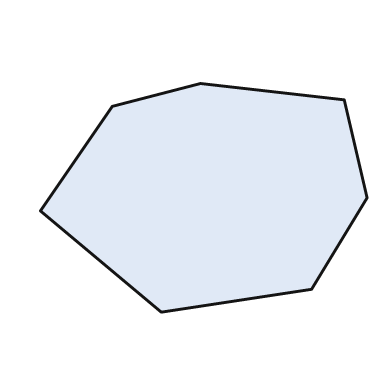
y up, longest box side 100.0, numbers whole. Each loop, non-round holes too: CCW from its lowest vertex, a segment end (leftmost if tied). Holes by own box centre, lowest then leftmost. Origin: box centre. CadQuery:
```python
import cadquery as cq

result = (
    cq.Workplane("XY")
    .moveTo(-13.0, -35.0)
    .lineTo(33.0, -28.0)
    .lineTo(50.0, 0.0)
    .lineTo(43.0, 30.0)
    .lineTo(-1.0, 35.0)
    .lineTo(-28.0, 28.0)
    .lineTo(-50.0, -4.0)
    .close()
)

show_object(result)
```